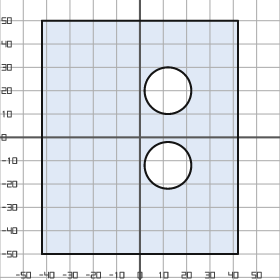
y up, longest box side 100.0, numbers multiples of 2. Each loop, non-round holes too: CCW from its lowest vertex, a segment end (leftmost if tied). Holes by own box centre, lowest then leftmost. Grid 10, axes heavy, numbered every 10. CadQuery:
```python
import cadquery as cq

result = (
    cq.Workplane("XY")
    .moveTo(-42.0, -50.0)
    .lineTo(42.0, -50.0)
    .lineTo(42.0, 50.0)
    .lineTo(-42.0, 50.0)
    .close()
    .moveTo(12.0, -12.0)
    .circle(10.0)
    .moveTo(12.0, 20.0)
    .circle(10.0)
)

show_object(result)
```